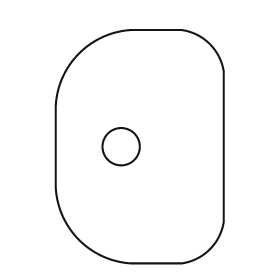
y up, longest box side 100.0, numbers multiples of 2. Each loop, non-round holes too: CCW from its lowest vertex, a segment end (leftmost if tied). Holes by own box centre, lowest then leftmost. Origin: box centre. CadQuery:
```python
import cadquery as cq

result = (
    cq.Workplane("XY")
    .moveTo(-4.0, -50.0)
    .lineTo(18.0, -50.0)
    .threePointArc((30.0, -44.0), (36.0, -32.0))
    .lineTo(36.0, 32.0)
    .threePointArc((30.0, 44.0), (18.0, 50.0))
    .lineTo(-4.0, 50.0)
    .threePointArc((-26.0, 40.0), (-36.0, 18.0))
    .lineTo(-36.0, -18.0)
    .threePointArc((-26.0, -40.0), (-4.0, -50.0))
    .close()
    .moveTo(-8.0, 0.0)
    .circle(8.0)
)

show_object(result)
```